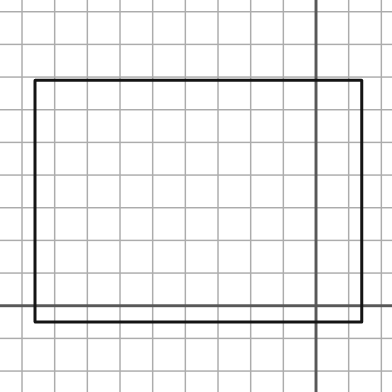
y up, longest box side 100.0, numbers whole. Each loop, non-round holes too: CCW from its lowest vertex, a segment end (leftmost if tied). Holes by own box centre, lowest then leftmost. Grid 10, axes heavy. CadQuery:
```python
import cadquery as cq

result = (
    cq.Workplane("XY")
    .moveTo(-86.0, -5.0)
    .lineTo(14.0, -5.0)
    .lineTo(14.0, 69.0)
    .lineTo(-86.0, 69.0)
    .close()
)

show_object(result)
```